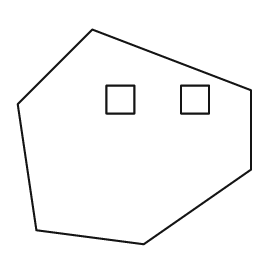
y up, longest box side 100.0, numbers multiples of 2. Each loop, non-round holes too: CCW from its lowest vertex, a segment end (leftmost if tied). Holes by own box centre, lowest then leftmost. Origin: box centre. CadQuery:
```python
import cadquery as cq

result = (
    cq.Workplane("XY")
    .moveTo(4.0, -46.0)
    .lineTo(50.0, -14.0)
    .lineTo(50.0, 20.0)
    .lineTo(-18.0, 46.0)
    .lineTo(-50.0, 14.0)
    .lineTo(-42.0, -40.0)
    .close()
    .moveTo(-12.0, 10.0)
    .lineTo(0.0, 10.0)
    .lineTo(0.0, 22.0)
    .lineTo(-12.0, 22.0)
    .close()
    .moveTo(20.0, 10.0)
    .lineTo(32.0, 10.0)
    .lineTo(32.0, 22.0)
    .lineTo(20.0, 22.0)
    .close()
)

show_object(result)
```